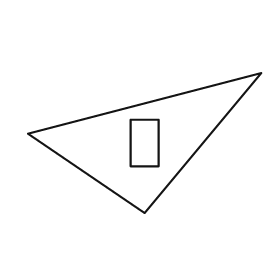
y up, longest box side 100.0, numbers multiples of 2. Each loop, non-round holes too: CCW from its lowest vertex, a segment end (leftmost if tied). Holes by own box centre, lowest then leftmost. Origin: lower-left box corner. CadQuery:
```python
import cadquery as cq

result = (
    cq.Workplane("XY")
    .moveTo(50.0, 0.0)
    .lineTo(100.0, 60.0)
    .lineTo(0.0, 34.0)
    .close()
    .moveTo(44.0, 20.0)
    .lineTo(56.0, 20.0)
    .lineTo(56.0, 40.0)
    .lineTo(44.0, 40.0)
    .close()
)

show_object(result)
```